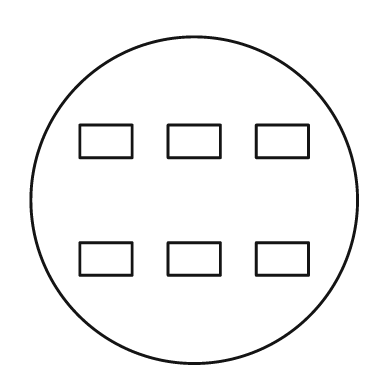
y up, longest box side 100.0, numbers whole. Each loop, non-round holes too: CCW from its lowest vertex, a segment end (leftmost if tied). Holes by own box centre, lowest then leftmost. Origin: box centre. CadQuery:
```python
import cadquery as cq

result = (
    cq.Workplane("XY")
    .moveTo(0.0, 0.0)
    .circle(50.0)
    .moveTo(-35.0, -23.0)
    .lineTo(-19.0, -23.0)
    .lineTo(-19.0, -13.0)
    .lineTo(-35.0, -13.0)
    .close()
    .moveTo(-8.0, -23.0)
    .lineTo(8.0, -23.0)
    .lineTo(8.0, -13.0)
    .lineTo(-8.0, -13.0)
    .close()
    .moveTo(19.0, -23.0)
    .lineTo(35.0, -23.0)
    .lineTo(35.0, -13.0)
    .lineTo(19.0, -13.0)
    .close()
    .moveTo(-35.0, 13.0)
    .lineTo(-19.0, 13.0)
    .lineTo(-19.0, 23.0)
    .lineTo(-35.0, 23.0)
    .close()
    .moveTo(-8.0, 13.0)
    .lineTo(8.0, 13.0)
    .lineTo(8.0, 23.0)
    .lineTo(-8.0, 23.0)
    .close()
    .moveTo(19.0, 13.0)
    .lineTo(35.0, 13.0)
    .lineTo(35.0, 23.0)
    .lineTo(19.0, 23.0)
    .close()
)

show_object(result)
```